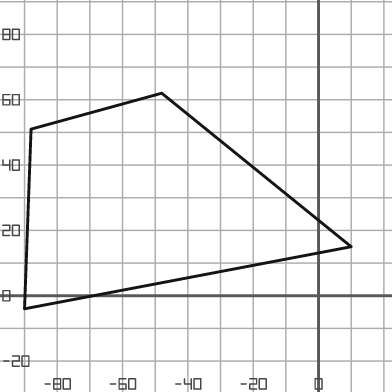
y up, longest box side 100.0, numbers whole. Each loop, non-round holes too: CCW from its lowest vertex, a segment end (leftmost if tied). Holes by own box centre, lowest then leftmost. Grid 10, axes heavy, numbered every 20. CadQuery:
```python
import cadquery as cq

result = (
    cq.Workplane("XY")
    .moveTo(-90.0, -4.0)
    .lineTo(10.0, 15.0)
    .lineTo(-48.0, 62.0)
    .lineTo(-88.0, 51.0)
    .close()
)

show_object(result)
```